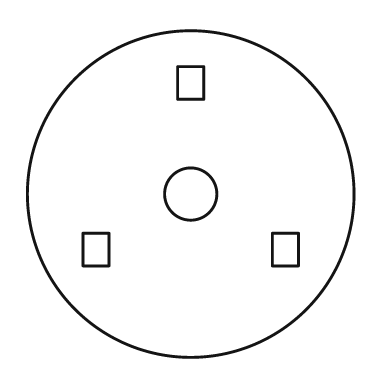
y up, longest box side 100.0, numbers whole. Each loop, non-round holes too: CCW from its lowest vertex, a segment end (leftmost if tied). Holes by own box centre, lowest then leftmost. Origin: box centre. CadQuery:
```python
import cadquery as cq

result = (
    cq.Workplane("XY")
    .moveTo(0.0, 0.0)
    .circle(50.0)
    .moveTo(-33.0, -22.0)
    .lineTo(-25.0, -22.0)
    .lineTo(-25.0, -12.0)
    .lineTo(-33.0, -12.0)
    .close()
    .moveTo(25.0, -22.0)
    .lineTo(33.0, -22.0)
    .lineTo(33.0, -12.0)
    .lineTo(25.0, -12.0)
    .close()
    .moveTo(0.0, 0.0)
    .circle(8.0)
    .moveTo(-4.0, 29.0)
    .lineTo(4.0, 29.0)
    .lineTo(4.0, 39.0)
    .lineTo(-4.0, 39.0)
    .close()
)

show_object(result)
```